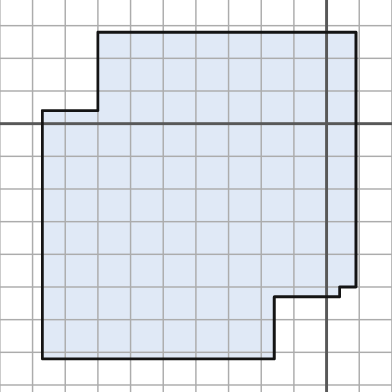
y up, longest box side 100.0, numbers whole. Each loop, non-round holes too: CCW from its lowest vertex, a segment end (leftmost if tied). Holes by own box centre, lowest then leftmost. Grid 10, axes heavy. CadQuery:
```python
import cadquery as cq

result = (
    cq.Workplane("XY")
    .moveTo(-87.0, -72.0)
    .lineTo(-16.0, -72.0)
    .lineTo(-16.0, -53.0)
    .lineTo(4.0, -53.0)
    .lineTo(4.0, -50.0)
    .lineTo(9.0, -50.0)
    .lineTo(9.0, 28.0)
    .lineTo(-70.0, 28.0)
    .lineTo(-70.0, 4.0)
    .lineTo(-87.0, 4.0)
    .close()
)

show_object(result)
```